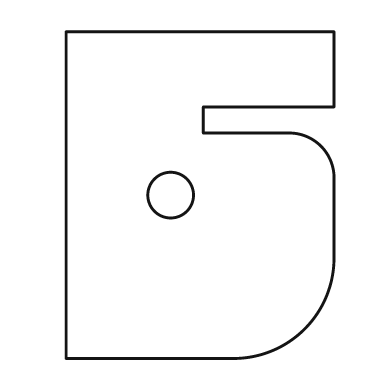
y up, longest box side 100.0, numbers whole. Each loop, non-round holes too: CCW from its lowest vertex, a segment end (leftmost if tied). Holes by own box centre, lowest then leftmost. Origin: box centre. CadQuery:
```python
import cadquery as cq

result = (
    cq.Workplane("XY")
    .moveTo(-41.0, -50.0)
    .lineTo(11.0, -50.0)
    .threePointArc((32.0, -41.0), (41.0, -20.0))
    .lineTo(41.0, 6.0)
    .threePointArc((37.0, 15.0), (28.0, 19.0))
    .lineTo(1.0, 19.0)
    .lineTo(1.0, 27.0)
    .lineTo(41.0, 27.0)
    .lineTo(41.0, 50.0)
    .lineTo(-41.0, 50.0)
    .close()
    .moveTo(-9.0, 0.0)
    .circle(7.0)
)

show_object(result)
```